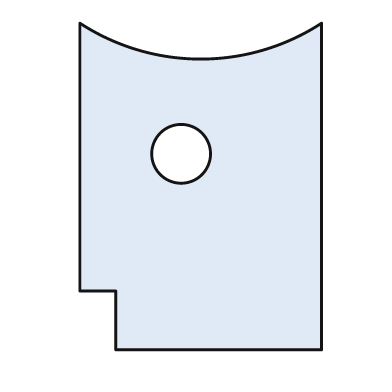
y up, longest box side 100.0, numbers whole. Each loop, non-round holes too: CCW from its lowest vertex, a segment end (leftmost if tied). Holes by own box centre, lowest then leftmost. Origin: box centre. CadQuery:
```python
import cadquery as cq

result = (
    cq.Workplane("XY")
    .moveTo(-26.0, -50.0)
    .lineTo(37.0, -50.0)
    .lineTo(37.0, 50.0)
    .threePointArc((0.0, 39.0), (-37.0, 50.0))
    .lineTo(-37.0, -32.0)
    .lineTo(-26.0, -32.0)
    .close()
    .moveTo(-6.0, 10.0)
    .circle(9.0)
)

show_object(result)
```